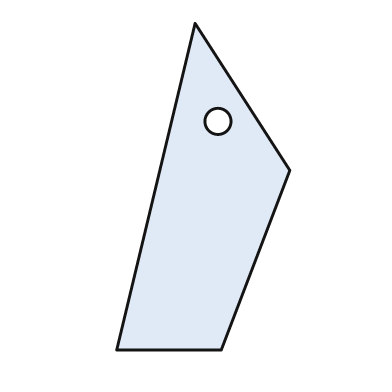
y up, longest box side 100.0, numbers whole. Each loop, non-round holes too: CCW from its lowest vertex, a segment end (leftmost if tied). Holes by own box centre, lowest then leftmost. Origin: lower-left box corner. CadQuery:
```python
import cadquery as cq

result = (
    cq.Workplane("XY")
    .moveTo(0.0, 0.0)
    .lineTo(32.0, 0.0)
    .lineTo(53.0, 55.0)
    .lineTo(24.0, 100.0)
    .close()
    .moveTo(31.0, 70.0)
    .circle(4.0)
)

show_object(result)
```